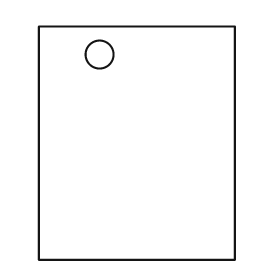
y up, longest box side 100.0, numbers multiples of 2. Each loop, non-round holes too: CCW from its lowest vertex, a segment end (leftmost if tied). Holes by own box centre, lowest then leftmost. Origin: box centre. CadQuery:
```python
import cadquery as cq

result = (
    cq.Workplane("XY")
    .moveTo(-42.0, -50.0)
    .lineTo(42.0, -50.0)
    .lineTo(42.0, 50.0)
    .lineTo(-42.0, 50.0)
    .close()
    .moveTo(-16.0, 38.0)
    .circle(6.0)
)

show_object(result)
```